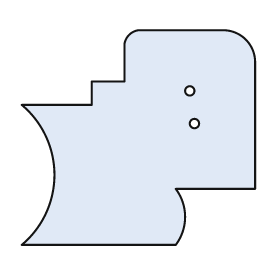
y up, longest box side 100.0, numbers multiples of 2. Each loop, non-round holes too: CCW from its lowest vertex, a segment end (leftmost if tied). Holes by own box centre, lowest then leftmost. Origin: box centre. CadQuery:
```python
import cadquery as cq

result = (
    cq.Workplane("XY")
    .moveTo(-50.0, -46.0)
    .lineTo(16.0, -46.0)
    .threePointArc((20.0, -34.0), (16.0, -22.0))
    .lineTo(50.0, -22.0)
    .lineTo(50.0, 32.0)
    .threePointArc((46.0, 42.0), (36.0, 46.0))
    .lineTo(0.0, 46.0)
    .threePointArc((-4.0, 44.0), (-6.0, 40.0))
    .lineTo(-6.0, 24.0)
    .lineTo(-20.0, 24.0)
    .lineTo(-20.0, 14.0)
    .lineTo(-50.0, 14.0)
    .threePointArc((-36.0, -16.0), (-50.0, -46.0))
    .close()
    .moveTo(24.0, 6.0)
    .circle(2.0)
    .moveTo(22.0, 20.0)
    .circle(2.0)
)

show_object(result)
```